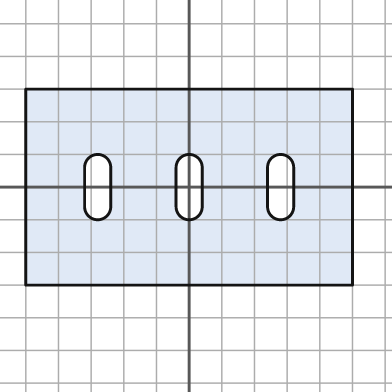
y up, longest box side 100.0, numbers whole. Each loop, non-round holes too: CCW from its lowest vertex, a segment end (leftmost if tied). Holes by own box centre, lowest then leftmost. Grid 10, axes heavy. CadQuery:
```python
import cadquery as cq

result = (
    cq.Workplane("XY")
    .moveTo(-50.0, -30.0)
    .lineTo(50.0, -30.0)
    .lineTo(50.0, 30.0)
    .lineTo(-50.0, 30.0)
    .close()
    .moveTo(-32.0, -6.0)
    .threePointArc((-28.0, -10.0), (-24.0, -6.0))
    .lineTo(-24.0, 6.0)
    .threePointArc((-28.0, 10.0), (-32.0, 6.0))
    .close()
    .moveTo(-4.0, -6.0)
    .threePointArc((0.0, -10.0), (4.0, -6.0))
    .lineTo(4.0, 6.0)
    .threePointArc((0.0, 10.0), (-4.0, 6.0))
    .close()
    .moveTo(24.0, -6.0)
    .threePointArc((28.0, -10.0), (32.0, -6.0))
    .lineTo(32.0, 6.0)
    .threePointArc((28.0, 10.0), (24.0, 6.0))
    .close()
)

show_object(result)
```